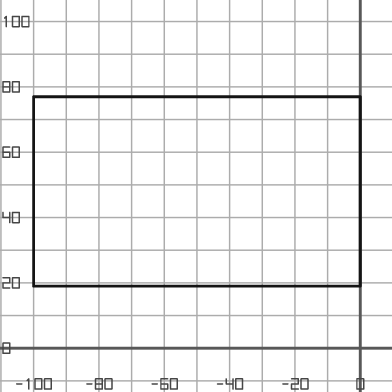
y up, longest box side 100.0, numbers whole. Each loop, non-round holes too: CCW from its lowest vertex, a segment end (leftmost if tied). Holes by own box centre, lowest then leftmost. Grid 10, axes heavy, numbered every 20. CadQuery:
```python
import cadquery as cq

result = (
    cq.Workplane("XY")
    .moveTo(-100.0, 19.0)
    .lineTo(0.0, 19.0)
    .lineTo(0.0, 77.0)
    .lineTo(-100.0, 77.0)
    .close()
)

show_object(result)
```